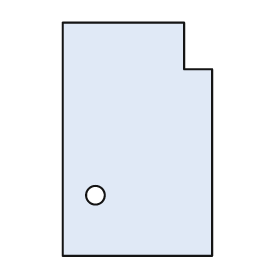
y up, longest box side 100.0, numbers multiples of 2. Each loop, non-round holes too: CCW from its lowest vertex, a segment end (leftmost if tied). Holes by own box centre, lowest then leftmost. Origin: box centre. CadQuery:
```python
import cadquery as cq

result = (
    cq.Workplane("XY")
    .moveTo(-32.0, -50.0)
    .lineTo(32.0, -50.0)
    .lineTo(32.0, 30.0)
    .lineTo(20.0, 30.0)
    .lineTo(20.0, 50.0)
    .lineTo(-32.0, 50.0)
    .close()
    .moveTo(-18.0, -24.0)
    .circle(4.0)
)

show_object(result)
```